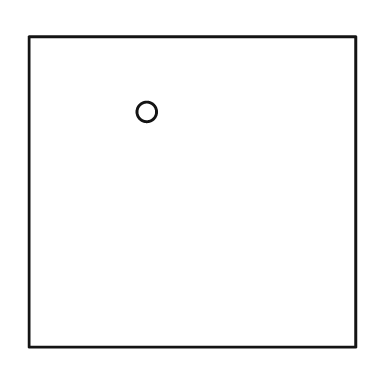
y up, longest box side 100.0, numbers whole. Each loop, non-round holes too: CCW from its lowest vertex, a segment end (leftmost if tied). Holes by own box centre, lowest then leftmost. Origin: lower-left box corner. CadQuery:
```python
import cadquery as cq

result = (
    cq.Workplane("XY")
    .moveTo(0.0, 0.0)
    .lineTo(100.0, 0.0)
    .lineTo(100.0, 95.0)
    .lineTo(0.0, 95.0)
    .close()
    .moveTo(36.0, 72.0)
    .circle(3.0)
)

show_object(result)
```